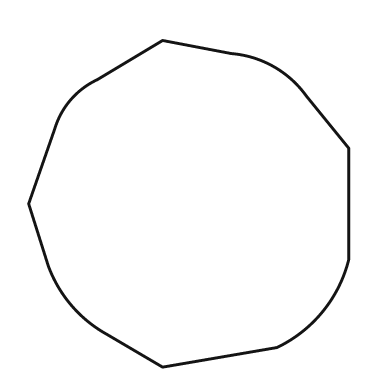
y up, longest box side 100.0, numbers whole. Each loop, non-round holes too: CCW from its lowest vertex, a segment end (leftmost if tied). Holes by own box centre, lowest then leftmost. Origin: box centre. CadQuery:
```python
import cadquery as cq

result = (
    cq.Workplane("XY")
    .moveTo(-8.0, -50.0)
    .lineTo(27.0, -44.0)
    .threePointArc((41.0, -33.0), (49.0, -17.0))
    .lineTo(49.0, 17.0)
    .lineTo(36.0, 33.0)
    .threePointArc((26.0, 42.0), (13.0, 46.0))
    .lineTo(-8.0, 50.0)
    .lineTo(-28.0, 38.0)
    .threePointArc((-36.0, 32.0), (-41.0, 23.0))
    .lineTo(-49.0, 0.0)
    .lineTo(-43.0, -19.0)
    .threePointArc((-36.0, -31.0), (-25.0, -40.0))
    .close()
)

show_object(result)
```